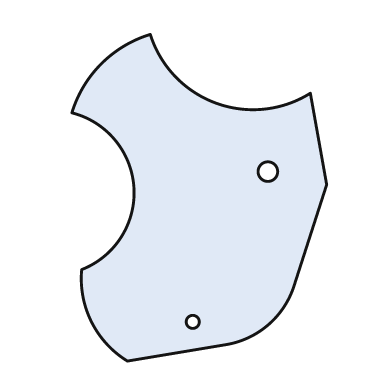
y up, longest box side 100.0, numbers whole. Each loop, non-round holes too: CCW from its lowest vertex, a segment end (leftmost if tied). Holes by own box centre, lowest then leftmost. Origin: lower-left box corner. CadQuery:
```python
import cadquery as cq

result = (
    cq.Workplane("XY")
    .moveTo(17.0, 0.0)
    .lineTo(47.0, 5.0)
    .threePointArc((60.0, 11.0), (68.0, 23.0))
    .lineTo(78.0, 54.0)
    .lineTo(73.0, 82.0)
    .threePointArc((44.0, 79.0), (24.0, 100.0))
    .threePointArc((9.0, 91.0), (0.0, 76.0))
    .threePointArc((19.0, 53.0), (3.0, 28.0))
    .threePointArc((6.0, 12.0), (17.0, 0.0))
    .close()
    .moveTo(37.0, 12.0)
    .circle(2.0)
    .moveTo(60.0, 58.0)
    .circle(3.0)
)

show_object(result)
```